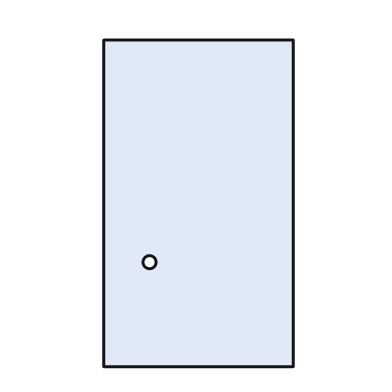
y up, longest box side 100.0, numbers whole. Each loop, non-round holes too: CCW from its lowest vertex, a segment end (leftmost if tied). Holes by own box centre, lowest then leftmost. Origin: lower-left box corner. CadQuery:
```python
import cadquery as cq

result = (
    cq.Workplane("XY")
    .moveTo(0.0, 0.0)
    .lineTo(58.0, 0.0)
    .lineTo(58.0, 100.0)
    .lineTo(0.0, 100.0)
    .close()
    .moveTo(14.0, 32.0)
    .circle(2.0)
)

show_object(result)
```